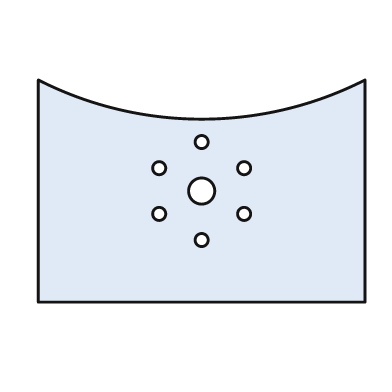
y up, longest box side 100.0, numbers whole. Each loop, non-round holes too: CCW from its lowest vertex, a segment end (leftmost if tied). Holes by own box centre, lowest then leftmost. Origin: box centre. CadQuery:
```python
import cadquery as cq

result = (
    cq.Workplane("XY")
    .moveTo(-50.0, -34.0)
    .lineTo(50.0, -34.0)
    .lineTo(50.0, 34.0)
    .threePointArc((0.0, 22.0), (-50.0, 34.0))
    .close()
    .moveTo(0.0, -15.0)
    .circle(2.0)
    .moveTo(-13.0, -7.0)
    .circle(2.0)
    .moveTo(13.0, -7.0)
    .circle(2.0)
    .moveTo(0.0, 0.0)
    .circle(4.0)
    .moveTo(-13.0, 7.0)
    .circle(2.0)
    .moveTo(13.0, 7.0)
    .circle(2.0)
    .moveTo(0.0, 15.0)
    .circle(2.0)
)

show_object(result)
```